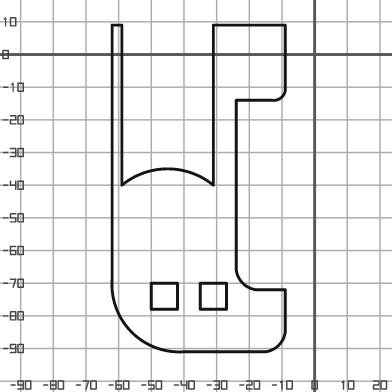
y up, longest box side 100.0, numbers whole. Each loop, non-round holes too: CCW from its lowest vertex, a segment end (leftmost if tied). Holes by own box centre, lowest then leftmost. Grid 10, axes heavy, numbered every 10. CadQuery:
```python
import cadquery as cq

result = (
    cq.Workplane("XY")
    .moveTo(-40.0, -91.0)
    .lineTo(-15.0, -91.0)
    .threePointArc((-11.0, -89.0), (-9.0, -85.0))
    .lineTo(-9.0, -72.0)
    .lineTo(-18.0, -72.0)
    .threePointArc((-22.0, -70.0), (-24.0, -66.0))
    .lineTo(-24.0, -14.0)
    .lineTo(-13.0, -14.0)
    .threePointArc((-10.0, -13.0), (-9.0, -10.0))
    .lineTo(-9.0, 9.0)
    .lineTo(-31.0, 9.0)
    .lineTo(-31.0, -40.0)
    .threePointArc((-45.0, -35.0), (-59.0, -40.0))
    .lineTo(-59.0, 9.0)
    .lineTo(-62.0, 9.0)
    .lineTo(-62.0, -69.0)
    .threePointArc((-56.0, -85.0), (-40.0, -91.0))
    .close()
    .moveTo(-50.0, -78.0)
    .lineTo(-42.0, -78.0)
    .lineTo(-42.0, -70.0)
    .lineTo(-50.0, -70.0)
    .close()
    .moveTo(-35.0, -78.0)
    .lineTo(-27.0, -78.0)
    .lineTo(-27.0, -70.0)
    .lineTo(-35.0, -70.0)
    .close()
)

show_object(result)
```